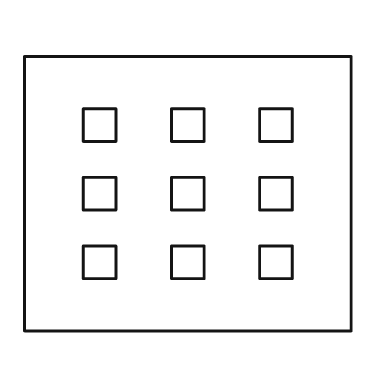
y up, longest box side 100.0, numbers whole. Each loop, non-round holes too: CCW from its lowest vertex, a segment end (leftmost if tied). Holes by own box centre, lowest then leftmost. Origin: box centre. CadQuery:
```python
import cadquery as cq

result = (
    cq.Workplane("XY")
    .moveTo(-50.0, -42.0)
    .lineTo(50.0, -42.0)
    .lineTo(50.0, 42.0)
    .lineTo(-50.0, 42.0)
    .close()
    .moveTo(-32.0, -26.0)
    .lineTo(-22.0, -26.0)
    .lineTo(-22.0, -16.0)
    .lineTo(-32.0, -16.0)
    .close()
    .moveTo(-5.0, -26.0)
    .lineTo(5.0, -26.0)
    .lineTo(5.0, -16.0)
    .lineTo(-5.0, -16.0)
    .close()
    .moveTo(22.0, -26.0)
    .lineTo(32.0, -26.0)
    .lineTo(32.0, -16.0)
    .lineTo(22.0, -16.0)
    .close()
    .moveTo(-32.0, -5.0)
    .lineTo(-22.0, -5.0)
    .lineTo(-22.0, 5.0)
    .lineTo(-32.0, 5.0)
    .close()
    .moveTo(-5.0, -5.0)
    .lineTo(5.0, -5.0)
    .lineTo(5.0, 5.0)
    .lineTo(-5.0, 5.0)
    .close()
    .moveTo(22.0, -5.0)
    .lineTo(32.0, -5.0)
    .lineTo(32.0, 5.0)
    .lineTo(22.0, 5.0)
    .close()
    .moveTo(-32.0, 16.0)
    .lineTo(-22.0, 16.0)
    .lineTo(-22.0, 26.0)
    .lineTo(-32.0, 26.0)
    .close()
    .moveTo(-5.0, 16.0)
    .lineTo(5.0, 16.0)
    .lineTo(5.0, 26.0)
    .lineTo(-5.0, 26.0)
    .close()
    .moveTo(22.0, 16.0)
    .lineTo(32.0, 16.0)
    .lineTo(32.0, 26.0)
    .lineTo(22.0, 26.0)
    .close()
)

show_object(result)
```